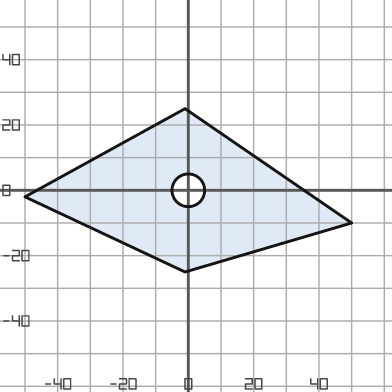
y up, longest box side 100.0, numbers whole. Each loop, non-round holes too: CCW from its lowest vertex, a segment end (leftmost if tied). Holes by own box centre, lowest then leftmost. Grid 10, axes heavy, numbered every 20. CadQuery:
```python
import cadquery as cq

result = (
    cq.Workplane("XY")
    .moveTo(-1.0, -25.0)
    .lineTo(50.0, -10.0)
    .lineTo(-1.0, 25.0)
    .lineTo(-50.0, -2.0)
    .close()
    .moveTo(0.0, 0.0)
    .circle(5.0)
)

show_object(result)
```